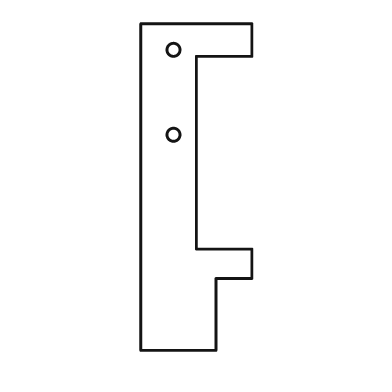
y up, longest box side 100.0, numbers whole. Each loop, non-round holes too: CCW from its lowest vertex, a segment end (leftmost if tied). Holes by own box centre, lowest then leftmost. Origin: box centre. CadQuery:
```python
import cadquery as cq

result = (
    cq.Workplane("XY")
    .moveTo(-17.0, -50.0)
    .lineTo(6.0, -50.0)
    .lineTo(6.0, -28.0)
    .lineTo(17.0, -28.0)
    .lineTo(17.0, -19.0)
    .lineTo(0.0, -19.0)
    .lineTo(0.0, 40.0)
    .lineTo(17.0, 40.0)
    .lineTo(17.0, 50.0)
    .lineTo(-17.0, 50.0)
    .close()
    .moveTo(-7.0, 16.0)
    .circle(2.0)
    .moveTo(-7.0, 42.0)
    .circle(2.0)
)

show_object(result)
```